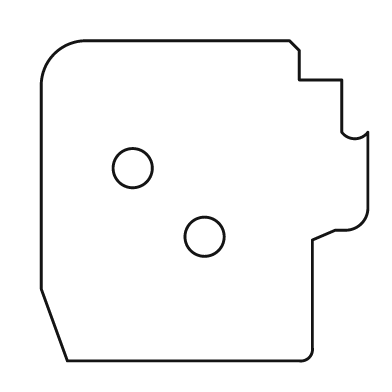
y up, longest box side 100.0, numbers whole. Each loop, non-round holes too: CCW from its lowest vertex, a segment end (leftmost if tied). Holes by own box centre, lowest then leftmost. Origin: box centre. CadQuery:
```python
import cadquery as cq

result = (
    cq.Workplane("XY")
    .moveTo(-42.0, -49.0)
    .lineTo(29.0, -49.0)
    .threePointArc((32.0, -48.0), (33.0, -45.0))
    .lineTo(33.0, -12.0)
    .lineTo(40.0, -9.0)
    .lineTo(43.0, -9.0)
    .threePointArc((48.0, -7.0), (50.0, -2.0))
    .lineTo(50.0, 21.0)
    .threePointArc((46.0, 19.0), (42.0, 21.0))
    .lineTo(42.0, 37.0)
    .lineTo(29.0, 37.0)
    .lineTo(29.0, 46.0)
    .lineTo(26.0, 49.0)
    .lineTo(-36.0, 49.0)
    .threePointArc((-46.0, 45.0), (-50.0, 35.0))
    .lineTo(-50.0, -27.0)
    .close()
    .moveTo(0.0, -11.0)
    .circle(6.0)
    .moveTo(-22.0, 10.0)
    .circle(6.0)
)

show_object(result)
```